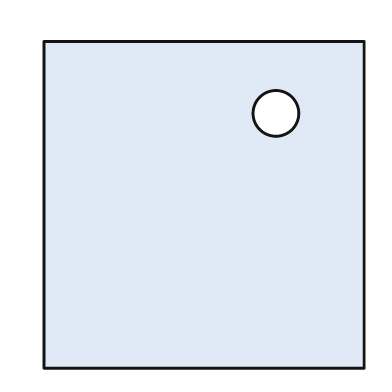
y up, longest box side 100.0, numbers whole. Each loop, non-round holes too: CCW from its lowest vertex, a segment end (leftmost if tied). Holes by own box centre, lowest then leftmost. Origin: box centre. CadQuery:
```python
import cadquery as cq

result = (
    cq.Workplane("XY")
    .moveTo(-49.0, -50.0)
    .lineTo(49.0, -50.0)
    .lineTo(49.0, 50.0)
    .lineTo(-49.0, 50.0)
    .close()
    .moveTo(22.0, 28.0)
    .circle(7.0)
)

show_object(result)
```